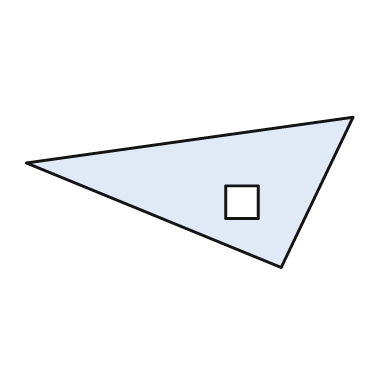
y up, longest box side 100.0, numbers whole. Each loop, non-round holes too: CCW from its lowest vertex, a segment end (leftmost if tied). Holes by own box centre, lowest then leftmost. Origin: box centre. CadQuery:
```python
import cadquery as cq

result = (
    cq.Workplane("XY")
    .moveTo(28.0, -23.0)
    .lineTo(50.0, 23.0)
    .lineTo(-50.0, 9.0)
    .close()
    .moveTo(11.0, -8.0)
    .lineTo(21.0, -8.0)
    .lineTo(21.0, 2.0)
    .lineTo(11.0, 2.0)
    .close()
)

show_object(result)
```